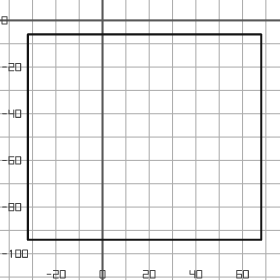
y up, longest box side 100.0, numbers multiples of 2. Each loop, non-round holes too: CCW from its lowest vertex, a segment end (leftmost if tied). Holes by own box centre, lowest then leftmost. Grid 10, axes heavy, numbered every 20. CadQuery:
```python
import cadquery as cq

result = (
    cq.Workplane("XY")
    .moveTo(-32.0, -94.0)
    .lineTo(68.0, -94.0)
    .lineTo(68.0, -6.0)
    .lineTo(-32.0, -6.0)
    .close()
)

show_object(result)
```